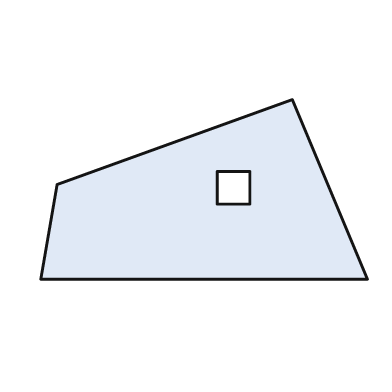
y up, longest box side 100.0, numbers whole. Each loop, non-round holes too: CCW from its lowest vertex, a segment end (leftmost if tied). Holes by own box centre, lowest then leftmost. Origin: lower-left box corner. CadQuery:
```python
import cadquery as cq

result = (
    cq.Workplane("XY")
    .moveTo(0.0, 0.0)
    .lineTo(100.0, 0.0)
    .lineTo(77.0, 55.0)
    .lineTo(5.0, 29.0)
    .close()
    .moveTo(54.0, 23.0)
    .lineTo(64.0, 23.0)
    .lineTo(64.0, 33.0)
    .lineTo(54.0, 33.0)
    .close()
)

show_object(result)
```